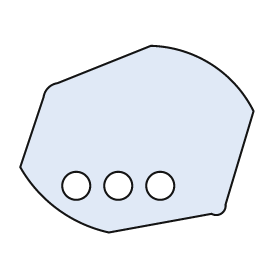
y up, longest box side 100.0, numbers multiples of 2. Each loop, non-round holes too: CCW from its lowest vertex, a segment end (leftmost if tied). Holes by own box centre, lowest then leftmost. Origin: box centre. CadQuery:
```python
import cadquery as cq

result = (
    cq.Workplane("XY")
    .moveTo(-12.0, -40.0)
    .lineTo(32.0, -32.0)
    .threePointArc((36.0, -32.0), (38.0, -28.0))
    .lineTo(50.0, 12.0)
    .threePointArc((32.0, 32.0), (6.0, 40.0))
    .lineTo(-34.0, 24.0)
    .threePointArc((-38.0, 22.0), (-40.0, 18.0))
    .lineTo(-50.0, -12.0)
    .threePointArc((-34.0, -30.0), (-12.0, -40.0))
    .close()
    .moveTo(-26.0, -20.0)
    .circle(6.0)
    .moveTo(-8.0, -20.0)
    .circle(6.0)
    .moveTo(10.0, -20.0)
    .circle(6.0)
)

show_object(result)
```